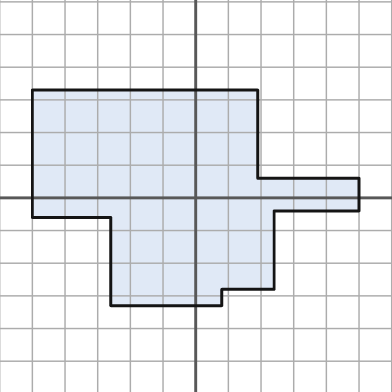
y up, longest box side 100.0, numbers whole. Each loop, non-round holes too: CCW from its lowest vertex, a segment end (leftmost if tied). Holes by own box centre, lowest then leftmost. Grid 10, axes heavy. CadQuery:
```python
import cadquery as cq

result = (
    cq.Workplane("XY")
    .moveTo(-26.0, -33.0)
    .lineTo(8.0, -33.0)
    .lineTo(8.0, -28.0)
    .lineTo(24.0, -28.0)
    .lineTo(24.0, -4.0)
    .lineTo(50.0, -4.0)
    .lineTo(50.0, 6.0)
    .lineTo(19.0, 6.0)
    .lineTo(19.0, 33.0)
    .lineTo(-50.0, 33.0)
    .lineTo(-50.0, -6.0)
    .lineTo(-26.0, -6.0)
    .close()
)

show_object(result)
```